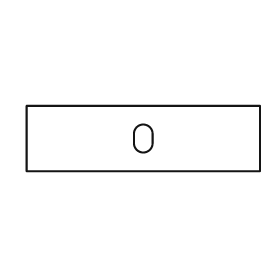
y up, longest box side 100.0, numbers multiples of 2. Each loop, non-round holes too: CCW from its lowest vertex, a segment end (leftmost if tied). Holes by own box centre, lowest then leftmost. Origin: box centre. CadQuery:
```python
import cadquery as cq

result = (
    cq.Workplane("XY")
    .moveTo(-50.0, -14.0)
    .lineTo(50.0, -14.0)
    .lineTo(50.0, 14.0)
    .lineTo(-50.0, 14.0)
    .close()
    .moveTo(-4.0, -2.0)
    .threePointArc((0.0, -6.0), (4.0, -2.0))
    .lineTo(4.0, 2.0)
    .threePointArc((0.0, 6.0), (-4.0, 2.0))
    .close()
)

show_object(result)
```